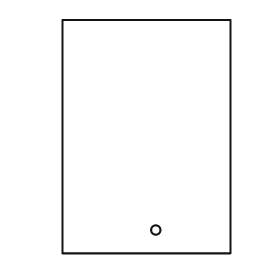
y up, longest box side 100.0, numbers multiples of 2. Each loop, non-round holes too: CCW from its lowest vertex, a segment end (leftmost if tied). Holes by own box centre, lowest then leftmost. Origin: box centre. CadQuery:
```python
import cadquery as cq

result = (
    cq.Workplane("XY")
    .moveTo(-36.0, -50.0)
    .lineTo(36.0, -50.0)
    .lineTo(36.0, 50.0)
    .lineTo(-36.0, 50.0)
    .close()
    .moveTo(4.0, -40.0)
    .circle(2.0)
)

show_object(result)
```